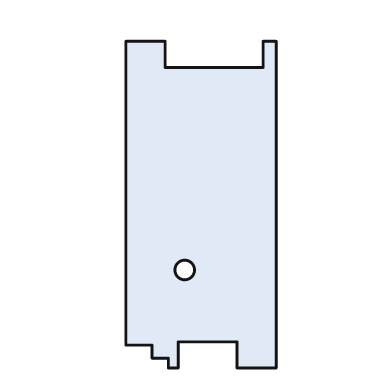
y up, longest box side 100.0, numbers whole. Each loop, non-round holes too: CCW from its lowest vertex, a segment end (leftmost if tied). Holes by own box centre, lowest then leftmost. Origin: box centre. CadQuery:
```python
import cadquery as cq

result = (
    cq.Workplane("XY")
    .moveTo(-10.0, -50.0)
    .lineTo(-7.0, -50.0)
    .lineTo(-7.0, -42.0)
    .lineTo(11.0, -42.0)
    .lineTo(11.0, -50.0)
    .lineTo(23.0, -50.0)
    .lineTo(23.0, 50.0)
    .lineTo(19.0, 50.0)
    .lineTo(19.0, 42.0)
    .lineTo(-11.0, 42.0)
    .lineTo(-11.0, 50.0)
    .lineTo(-23.0, 50.0)
    .lineTo(-23.0, -43.0)
    .lineTo(-15.0, -43.0)
    .lineTo(-15.0, -47.0)
    .lineTo(-10.0, -47.0)
    .close()
    .moveTo(-5.0, -20.0)
    .circle(3.0)
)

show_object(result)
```